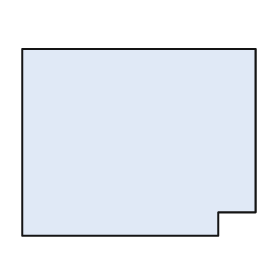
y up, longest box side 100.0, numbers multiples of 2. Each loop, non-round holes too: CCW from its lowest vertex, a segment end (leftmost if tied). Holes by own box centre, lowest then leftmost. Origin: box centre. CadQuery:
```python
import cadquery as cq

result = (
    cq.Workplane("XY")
    .moveTo(-50.0, -40.0)
    .lineTo(34.0, -40.0)
    .lineTo(34.0, -30.0)
    .lineTo(50.0, -30.0)
    .lineTo(50.0, 40.0)
    .lineTo(-50.0, 40.0)
    .close()
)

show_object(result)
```